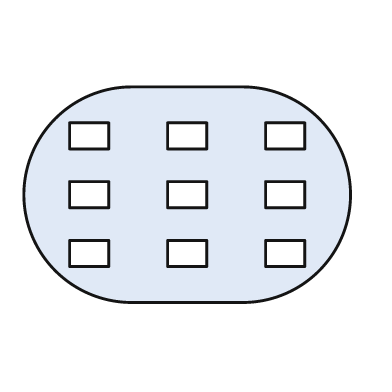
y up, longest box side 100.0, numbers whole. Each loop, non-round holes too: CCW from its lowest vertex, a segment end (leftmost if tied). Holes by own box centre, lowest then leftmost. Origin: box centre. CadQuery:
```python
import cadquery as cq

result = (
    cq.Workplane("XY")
    .moveTo(-17.0, -33.0)
    .lineTo(17.0, -33.0)
    .threePointArc((50.0, 0.0), (17.0, 33.0))
    .lineTo(-17.0, 33.0)
    .threePointArc((-50.0, 0.0), (-17.0, -33.0))
    .close()
    .moveTo(-36.0, -22.0)
    .lineTo(-24.0, -22.0)
    .lineTo(-24.0, -14.0)
    .lineTo(-36.0, -14.0)
    .close()
    .moveTo(-6.0, -22.0)
    .lineTo(6.0, -22.0)
    .lineTo(6.0, -14.0)
    .lineTo(-6.0, -14.0)
    .close()
    .moveTo(24.0, -22.0)
    .lineTo(36.0, -22.0)
    .lineTo(36.0, -14.0)
    .lineTo(24.0, -14.0)
    .close()
    .moveTo(-36.0, -4.0)
    .lineTo(-24.0, -4.0)
    .lineTo(-24.0, 4.0)
    .lineTo(-36.0, 4.0)
    .close()
    .moveTo(-6.0, -4.0)
    .lineTo(6.0, -4.0)
    .lineTo(6.0, 4.0)
    .lineTo(-6.0, 4.0)
    .close()
    .moveTo(24.0, -4.0)
    .lineTo(36.0, -4.0)
    .lineTo(36.0, 4.0)
    .lineTo(24.0, 4.0)
    .close()
    .moveTo(-36.0, 14.0)
    .lineTo(-24.0, 14.0)
    .lineTo(-24.0, 22.0)
    .lineTo(-36.0, 22.0)
    .close()
    .moveTo(-6.0, 14.0)
    .lineTo(6.0, 14.0)
    .lineTo(6.0, 22.0)
    .lineTo(-6.0, 22.0)
    .close()
    .moveTo(24.0, 14.0)
    .lineTo(36.0, 14.0)
    .lineTo(36.0, 22.0)
    .lineTo(24.0, 22.0)
    .close()
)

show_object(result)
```